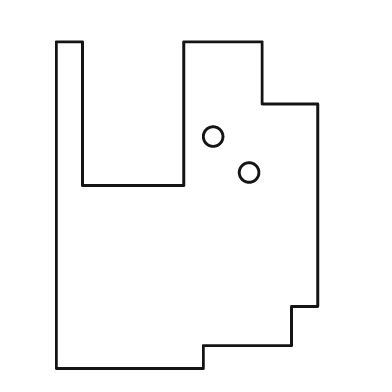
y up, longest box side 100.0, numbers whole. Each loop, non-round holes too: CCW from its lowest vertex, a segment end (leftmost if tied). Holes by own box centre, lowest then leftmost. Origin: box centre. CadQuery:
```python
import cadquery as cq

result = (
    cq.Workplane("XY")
    .moveTo(-40.0, -50.0)
    .lineTo(5.0, -50.0)
    .lineTo(5.0, -43.0)
    .lineTo(32.0, -43.0)
    .lineTo(32.0, -31.0)
    .lineTo(40.0, -31.0)
    .lineTo(40.0, 31.0)
    .lineTo(23.0, 31.0)
    .lineTo(23.0, 50.0)
    .lineTo(-1.0, 50.0)
    .lineTo(-1.0, 6.0)
    .lineTo(-32.0, 6.0)
    .lineTo(-32.0, 50.0)
    .lineTo(-40.0, 50.0)
    .close()
    .moveTo(19.0, 10.0)
    .circle(3.0)
    .moveTo(8.0, 21.0)
    .circle(3.0)
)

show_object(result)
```